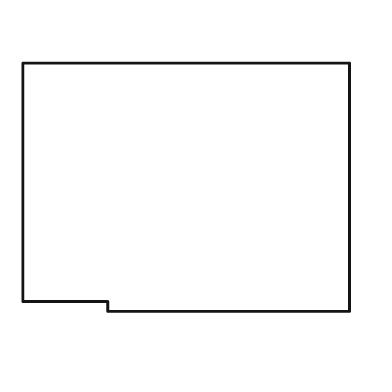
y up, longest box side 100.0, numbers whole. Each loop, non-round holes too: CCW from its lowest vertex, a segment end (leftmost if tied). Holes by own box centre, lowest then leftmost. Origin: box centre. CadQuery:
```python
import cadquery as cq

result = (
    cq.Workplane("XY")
    .moveTo(-24.0, -38.0)
    .lineTo(50.0, -38.0)
    .lineTo(50.0, 38.0)
    .lineTo(-50.0, 38.0)
    .lineTo(-50.0, -35.0)
    .lineTo(-24.0, -35.0)
    .close()
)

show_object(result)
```